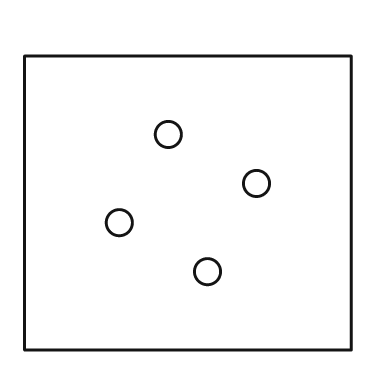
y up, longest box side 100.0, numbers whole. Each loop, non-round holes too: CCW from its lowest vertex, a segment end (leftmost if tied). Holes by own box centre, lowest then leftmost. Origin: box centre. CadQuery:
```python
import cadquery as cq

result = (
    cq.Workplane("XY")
    .moveTo(-50.0, -45.0)
    .lineTo(50.0, -45.0)
    .lineTo(50.0, 45.0)
    .lineTo(-50.0, 45.0)
    .close()
    .moveTo(6.0, -21.0)
    .circle(4.0)
    .moveTo(-21.0, -6.0)
    .circle(4.0)
    .moveTo(21.0, 6.0)
    .circle(4.0)
    .moveTo(-6.0, 21.0)
    .circle(4.0)
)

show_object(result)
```